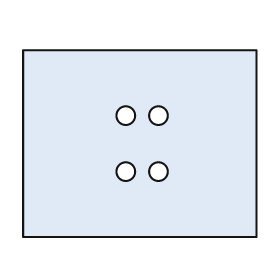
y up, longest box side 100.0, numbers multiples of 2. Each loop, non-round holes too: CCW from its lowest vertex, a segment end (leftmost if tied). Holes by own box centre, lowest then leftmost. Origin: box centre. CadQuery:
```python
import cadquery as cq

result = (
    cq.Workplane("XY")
    .moveTo(-50.0, -40.0)
    .lineTo(50.0, -40.0)
    .lineTo(50.0, 40.0)
    .lineTo(-50.0, 40.0)
    .close()
    .moveTo(-6.0, -12.0)
    .circle(4.0)
    .moveTo(8.0, -12.0)
    .circle(4.0)
    .moveTo(-6.0, 12.0)
    .circle(4.0)
    .moveTo(8.0, 12.0)
    .circle(4.0)
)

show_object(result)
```